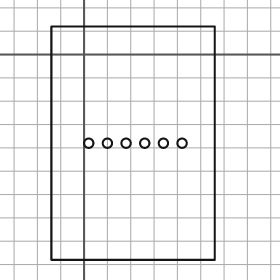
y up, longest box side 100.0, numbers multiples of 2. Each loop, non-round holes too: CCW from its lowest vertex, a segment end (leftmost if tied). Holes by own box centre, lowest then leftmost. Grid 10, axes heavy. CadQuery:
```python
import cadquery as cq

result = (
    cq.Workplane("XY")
    .moveTo(-14.0, -88.0)
    .lineTo(56.0, -88.0)
    .lineTo(56.0, 12.0)
    .lineTo(-14.0, 12.0)
    .close()
    .moveTo(2.0, -38.0)
    .circle(2.0)
    .moveTo(10.0, -38.0)
    .circle(2.0)
    .moveTo(18.0, -38.0)
    .circle(2.0)
    .moveTo(26.0, -38.0)
    .circle(2.0)
    .moveTo(34.0, -38.0)
    .circle(2.0)
    .moveTo(42.0, -38.0)
    .circle(2.0)
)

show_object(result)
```